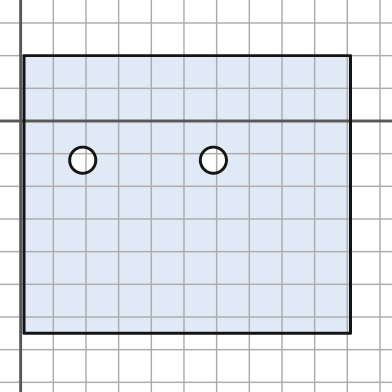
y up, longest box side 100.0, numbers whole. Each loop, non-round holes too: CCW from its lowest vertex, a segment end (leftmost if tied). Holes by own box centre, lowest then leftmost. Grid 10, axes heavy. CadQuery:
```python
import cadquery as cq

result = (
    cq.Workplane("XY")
    .moveTo(1.0, -65.0)
    .lineTo(101.0, -65.0)
    .lineTo(101.0, 20.0)
    .lineTo(1.0, 20.0)
    .close()
    .moveTo(19.0, -12.0)
    .circle(4.0)
    .moveTo(59.0, -12.0)
    .circle(4.0)
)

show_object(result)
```